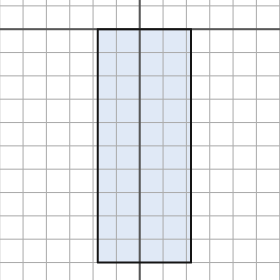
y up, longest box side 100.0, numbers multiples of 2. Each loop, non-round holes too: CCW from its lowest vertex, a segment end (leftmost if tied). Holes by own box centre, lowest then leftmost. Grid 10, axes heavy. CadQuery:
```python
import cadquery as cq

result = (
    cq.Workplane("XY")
    .moveTo(-18.0, -100.0)
    .lineTo(22.0, -100.0)
    .lineTo(22.0, 0.0)
    .lineTo(-18.0, 0.0)
    .close()
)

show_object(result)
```